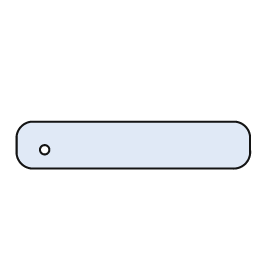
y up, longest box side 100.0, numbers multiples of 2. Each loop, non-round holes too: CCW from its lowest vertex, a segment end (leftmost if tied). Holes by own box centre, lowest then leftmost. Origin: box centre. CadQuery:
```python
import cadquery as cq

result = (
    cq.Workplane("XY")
    .moveTo(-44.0, -10.0)
    .lineTo(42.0, -10.0)
    .threePointArc((48.0, -8.0), (50.0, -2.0))
    .lineTo(50.0, 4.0)
    .threePointArc((48.0, 8.0), (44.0, 10.0))
    .lineTo(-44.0, 10.0)
    .threePointArc((-48.0, 8.0), (-50.0, 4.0))
    .lineTo(-50.0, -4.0)
    .threePointArc((-48.0, -8.0), (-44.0, -10.0))
    .close()
    .moveTo(-38.0, -2.0)
    .circle(2.0)
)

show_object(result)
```